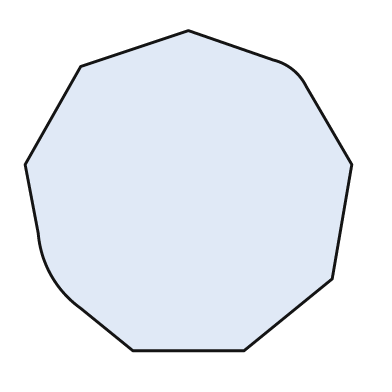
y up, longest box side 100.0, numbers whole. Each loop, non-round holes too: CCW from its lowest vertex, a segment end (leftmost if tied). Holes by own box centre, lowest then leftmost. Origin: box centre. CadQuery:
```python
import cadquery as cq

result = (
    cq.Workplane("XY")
    .moveTo(-17.0, -49.0)
    .lineTo(17.0, -49.0)
    .lineTo(44.0, -27.0)
    .lineTo(50.0, 8.0)
    .lineTo(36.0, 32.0)
    .threePointArc((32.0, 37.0), (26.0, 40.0))
    .lineTo(0.0, 49.0)
    .lineTo(-33.0, 38.0)
    .lineTo(-50.0, 8.0)
    .lineTo(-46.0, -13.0)
    .threePointArc((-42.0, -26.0), (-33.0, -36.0))
    .close()
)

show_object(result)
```